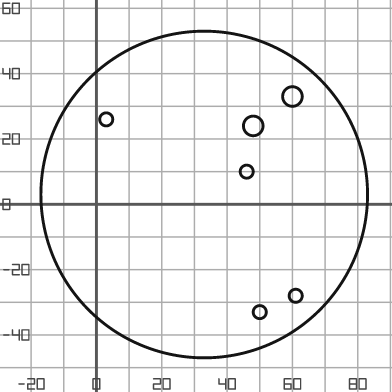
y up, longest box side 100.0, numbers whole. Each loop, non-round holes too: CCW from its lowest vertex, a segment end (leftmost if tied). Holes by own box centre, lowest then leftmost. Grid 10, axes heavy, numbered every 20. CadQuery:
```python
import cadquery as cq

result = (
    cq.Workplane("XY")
    .moveTo(33.0, 3.0)
    .circle(50.0)
    .moveTo(50.0, -33.0)
    .circle(2.0)
    .moveTo(61.0, -28.0)
    .circle(2.0)
    .moveTo(46.0, 10.0)
    .circle(2.0)
    .moveTo(48.0, 24.0)
    .circle(3.0)
    .moveTo(3.0, 26.0)
    .circle(2.0)
    .moveTo(60.0, 33.0)
    .circle(3.0)
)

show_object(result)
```